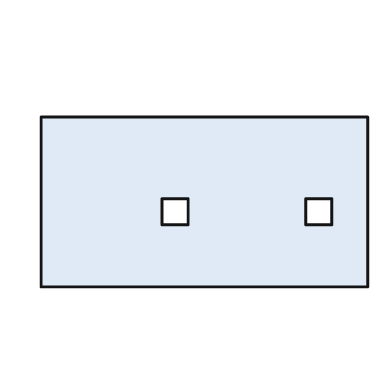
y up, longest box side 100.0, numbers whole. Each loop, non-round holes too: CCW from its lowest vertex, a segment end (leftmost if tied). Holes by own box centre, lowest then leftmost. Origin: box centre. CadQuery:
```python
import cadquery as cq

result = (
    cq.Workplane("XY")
    .moveTo(-50.0, -26.0)
    .lineTo(50.0, -26.0)
    .lineTo(50.0, 26.0)
    .lineTo(-50.0, 26.0)
    .close()
    .moveTo(-13.0, -7.0)
    .lineTo(-5.0, -7.0)
    .lineTo(-5.0, 1.0)
    .lineTo(-13.0, 1.0)
    .close()
    .moveTo(31.0, -7.0)
    .lineTo(39.0, -7.0)
    .lineTo(39.0, 1.0)
    .lineTo(31.0, 1.0)
    .close()
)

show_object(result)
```